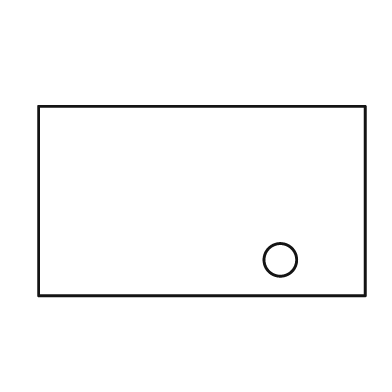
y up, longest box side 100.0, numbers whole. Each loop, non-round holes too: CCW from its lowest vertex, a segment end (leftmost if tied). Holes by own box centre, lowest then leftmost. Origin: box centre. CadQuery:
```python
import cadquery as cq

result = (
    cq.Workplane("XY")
    .moveTo(-50.0, -29.0)
    .lineTo(50.0, -29.0)
    .lineTo(50.0, 29.0)
    .lineTo(-50.0, 29.0)
    .close()
    .moveTo(24.0, -18.0)
    .circle(5.0)
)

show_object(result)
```